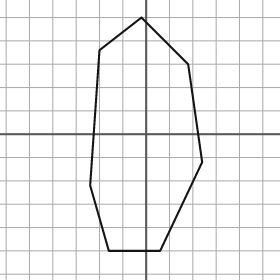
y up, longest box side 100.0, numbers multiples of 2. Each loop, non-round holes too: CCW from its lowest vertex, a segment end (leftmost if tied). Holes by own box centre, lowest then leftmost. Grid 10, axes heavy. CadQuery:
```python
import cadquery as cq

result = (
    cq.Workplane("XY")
    .moveTo(-16.0, -50.0)
    .lineTo(6.0, -50.0)
    .lineTo(24.0, -12.0)
    .lineTo(18.0, 30.0)
    .lineTo(-2.0, 50.0)
    .lineTo(-20.0, 36.0)
    .lineTo(-24.0, -22.0)
    .close()
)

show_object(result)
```